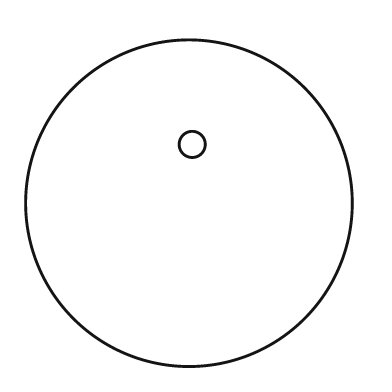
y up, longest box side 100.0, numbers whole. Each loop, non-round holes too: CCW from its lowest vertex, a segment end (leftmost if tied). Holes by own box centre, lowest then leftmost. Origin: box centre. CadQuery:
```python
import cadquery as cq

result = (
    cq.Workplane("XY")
    .moveTo(0.0, 0.0)
    .circle(50.0)
    .moveTo(1.0, 18.0)
    .circle(4.0)
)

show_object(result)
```